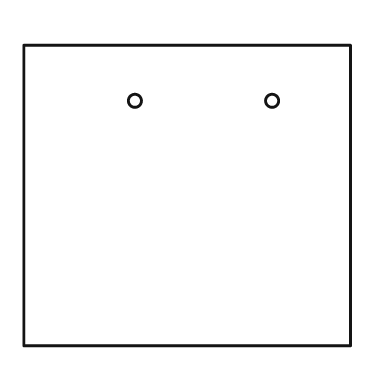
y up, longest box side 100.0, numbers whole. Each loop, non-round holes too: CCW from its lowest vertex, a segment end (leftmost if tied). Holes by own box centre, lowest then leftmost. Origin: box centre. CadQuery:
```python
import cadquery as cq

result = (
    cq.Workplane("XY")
    .moveTo(-50.0, -46.0)
    .lineTo(50.0, -46.0)
    .lineTo(50.0, 46.0)
    .lineTo(-50.0, 46.0)
    .close()
    .moveTo(-16.0, 29.0)
    .circle(2.0)
    .moveTo(26.0, 29.0)
    .circle(2.0)
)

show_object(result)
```